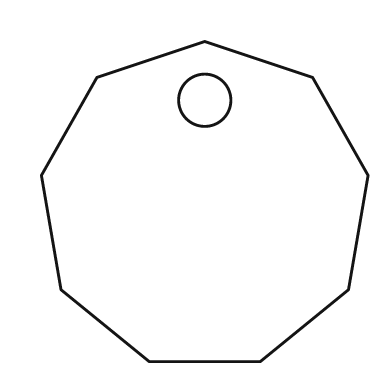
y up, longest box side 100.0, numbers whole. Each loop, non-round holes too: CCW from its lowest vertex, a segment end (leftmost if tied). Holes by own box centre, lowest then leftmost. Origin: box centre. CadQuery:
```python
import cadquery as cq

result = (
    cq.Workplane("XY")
    .moveTo(-17.0, -49.0)
    .lineTo(17.0, -49.0)
    .lineTo(44.0, -27.0)
    .lineTo(50.0, 8.0)
    .lineTo(33.0, 38.0)
    .lineTo(0.0, 49.0)
    .lineTo(-33.0, 38.0)
    .lineTo(-50.0, 8.0)
    .lineTo(-44.0, -27.0)
    .close()
    .moveTo(0.0, 31.0)
    .circle(8.0)
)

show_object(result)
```